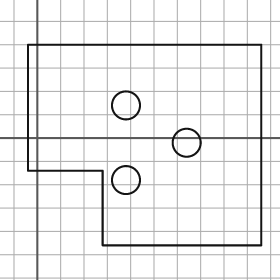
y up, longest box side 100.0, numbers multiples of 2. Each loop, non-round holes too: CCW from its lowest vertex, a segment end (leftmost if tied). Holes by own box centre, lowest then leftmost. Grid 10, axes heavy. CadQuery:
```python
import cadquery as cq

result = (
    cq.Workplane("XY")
    .moveTo(28.0, -46.0)
    .lineTo(96.0, -46.0)
    .lineTo(96.0, 40.0)
    .lineTo(-4.0, 40.0)
    .lineTo(-4.0, -14.0)
    .lineTo(28.0, -14.0)
    .close()
    .moveTo(38.0, -18.0)
    .circle(6.0)
    .moveTo(64.0, -2.0)
    .circle(6.0)
    .moveTo(38.0, 14.0)
    .circle(6.0)
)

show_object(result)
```